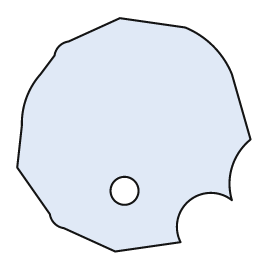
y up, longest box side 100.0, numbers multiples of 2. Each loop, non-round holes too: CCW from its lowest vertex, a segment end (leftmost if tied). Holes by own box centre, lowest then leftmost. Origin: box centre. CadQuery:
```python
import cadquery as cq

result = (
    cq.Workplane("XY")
    .moveTo(-8.0, -50.0)
    .lineTo(20.0, -46.0)
    .threePointArc((24.0, -28.0), (42.0, -28.0))
    .threePointArc((42.0, -14.0), (50.0, -2.0))
    .lineTo(42.0, 26.0)
    .threePointArc((34.0, 38.0), (22.0, 46.0))
    .lineTo(-6.0, 50.0)
    .lineTo(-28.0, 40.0)
    .threePointArc((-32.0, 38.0), (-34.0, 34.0))
    .lineTo(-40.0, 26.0)
    .threePointArc((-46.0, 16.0), (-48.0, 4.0))
    .lineTo(-50.0, -14.0)
    .lineTo(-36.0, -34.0)
    .threePointArc((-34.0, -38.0), (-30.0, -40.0))
    .close()
    .moveTo(-4.0, -24.0)
    .circle(6.0)
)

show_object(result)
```